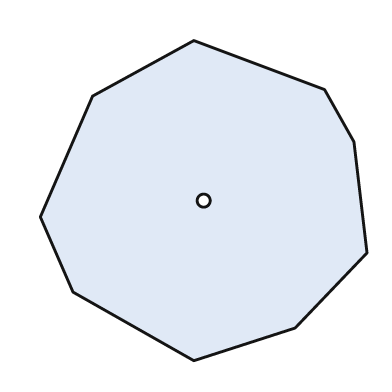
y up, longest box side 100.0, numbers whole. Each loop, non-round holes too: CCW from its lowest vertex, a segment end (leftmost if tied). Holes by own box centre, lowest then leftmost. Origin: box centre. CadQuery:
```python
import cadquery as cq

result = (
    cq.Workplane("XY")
    .moveTo(-3.0, -49.0)
    .lineTo(28.0, -39.0)
    .lineTo(50.0, -16.0)
    .lineTo(46.0, 18.0)
    .lineTo(37.0, 34.0)
    .lineTo(-3.0, 49.0)
    .lineTo(-34.0, 32.0)
    .lineTo(-50.0, -5.0)
    .lineTo(-40.0, -28.0)
    .close()
    .moveTo(0.0, 0.0)
    .circle(2.0)
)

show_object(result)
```